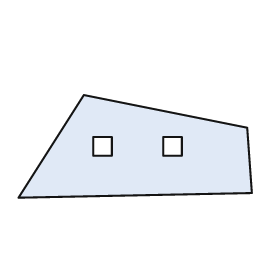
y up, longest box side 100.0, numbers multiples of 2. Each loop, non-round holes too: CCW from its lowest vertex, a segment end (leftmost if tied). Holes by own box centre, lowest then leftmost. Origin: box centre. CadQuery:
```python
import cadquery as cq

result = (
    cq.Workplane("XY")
    .moveTo(-50.0, -22.0)
    .lineTo(50.0, -20.0)
    .lineTo(48.0, 8.0)
    .lineTo(-22.0, 22.0)
    .close()
    .moveTo(-18.0, -4.0)
    .lineTo(-10.0, -4.0)
    .lineTo(-10.0, 4.0)
    .lineTo(-18.0, 4.0)
    .close()
    .moveTo(12.0, -4.0)
    .lineTo(20.0, -4.0)
    .lineTo(20.0, 4.0)
    .lineTo(12.0, 4.0)
    .close()
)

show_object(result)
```